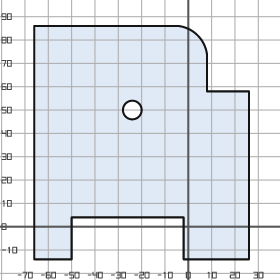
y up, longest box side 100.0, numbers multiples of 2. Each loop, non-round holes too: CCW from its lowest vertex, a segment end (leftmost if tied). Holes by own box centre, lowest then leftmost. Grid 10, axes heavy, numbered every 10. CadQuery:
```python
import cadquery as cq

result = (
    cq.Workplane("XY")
    .moveTo(-66.0, -14.0)
    .lineTo(-50.0, -14.0)
    .lineTo(-50.0, 4.0)
    .lineTo(-2.0, 4.0)
    .lineTo(-2.0, -14.0)
    .lineTo(26.0, -14.0)
    .lineTo(26.0, 58.0)
    .lineTo(8.0, 58.0)
    .lineTo(8.0, 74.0)
    .threePointArc((4.0, 82.0), (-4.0, 86.0))
    .lineTo(-66.0, 86.0)
    .close()
    .moveTo(-24.0, 50.0)
    .circle(4.0)
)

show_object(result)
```